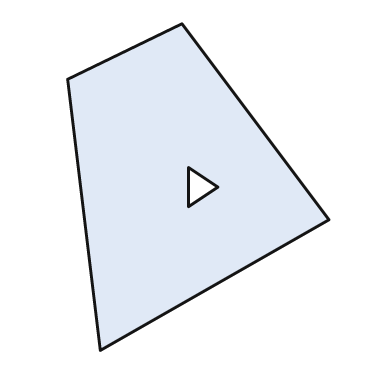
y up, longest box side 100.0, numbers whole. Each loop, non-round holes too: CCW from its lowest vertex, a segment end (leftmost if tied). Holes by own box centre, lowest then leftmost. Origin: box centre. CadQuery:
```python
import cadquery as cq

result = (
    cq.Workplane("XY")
    .moveTo(-30.0, -50.0)
    .lineTo(40.0, -10.0)
    .lineTo(-5.0, 50.0)
    .lineTo(-40.0, 33.0)
    .close()
    .moveTo(-3.0, -6.0)
    .lineTo(6.0, 0.0)
    .lineTo(-3.0, 6.0)
    .close()
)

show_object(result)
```